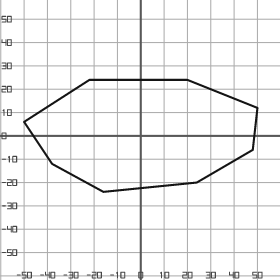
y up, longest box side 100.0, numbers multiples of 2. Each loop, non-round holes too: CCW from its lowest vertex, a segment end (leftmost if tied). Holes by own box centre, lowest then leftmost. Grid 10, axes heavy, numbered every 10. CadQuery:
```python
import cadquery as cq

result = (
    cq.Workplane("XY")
    .moveTo(-16.0, -24.0)
    .lineTo(24.0, -20.0)
    .lineTo(48.0, -6.0)
    .lineTo(50.0, 12.0)
    .lineTo(20.0, 24.0)
    .lineTo(-22.0, 24.0)
    .lineTo(-50.0, 6.0)
    .lineTo(-38.0, -12.0)
    .close()
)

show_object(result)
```